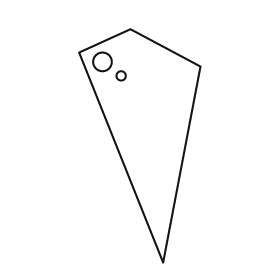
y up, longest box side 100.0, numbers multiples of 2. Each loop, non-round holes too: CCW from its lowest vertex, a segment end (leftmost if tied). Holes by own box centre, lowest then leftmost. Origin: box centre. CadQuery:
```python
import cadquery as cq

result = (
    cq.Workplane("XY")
    .moveTo(10.0, -50.0)
    .lineTo(26.0, 34.0)
    .lineTo(-4.0, 50.0)
    .lineTo(-26.0, 40.0)
    .close()
    .moveTo(-8.0, 30.0)
    .circle(2.0)
    .moveTo(-16.0, 36.0)
    .circle(4.0)
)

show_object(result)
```